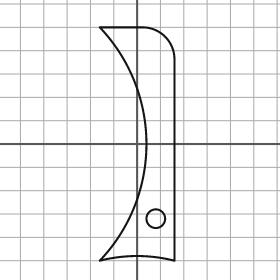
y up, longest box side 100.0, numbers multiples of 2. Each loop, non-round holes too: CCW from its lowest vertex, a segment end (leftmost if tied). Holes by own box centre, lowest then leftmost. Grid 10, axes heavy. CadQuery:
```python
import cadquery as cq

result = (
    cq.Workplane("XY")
    .moveTo(-16.0, -50.0)
    .threePointArc((0.0, -48.0), (16.0, -50.0))
    .lineTo(16.0, 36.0)
    .threePointArc((12.0, 46.0), (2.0, 50.0))
    .lineTo(-16.0, 50.0)
    .threePointArc((4.0, 0.0), (-16.0, -50.0))
    .close()
    .moveTo(8.0, -32.0)
    .circle(4.0)
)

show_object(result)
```